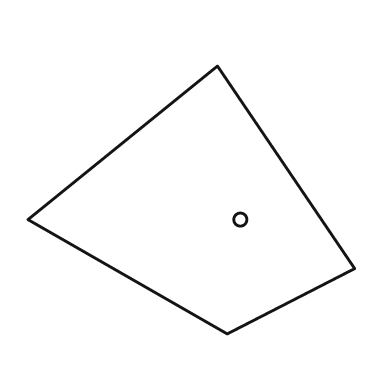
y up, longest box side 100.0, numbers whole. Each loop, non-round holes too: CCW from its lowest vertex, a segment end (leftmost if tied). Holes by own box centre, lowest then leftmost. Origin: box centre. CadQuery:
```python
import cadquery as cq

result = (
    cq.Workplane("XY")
    .moveTo(11.0, -41.0)
    .lineTo(50.0, -21.0)
    .lineTo(8.0, 41.0)
    .lineTo(-50.0, -6.0)
    .close()
    .moveTo(15.0, -6.0)
    .circle(2.0)
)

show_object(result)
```